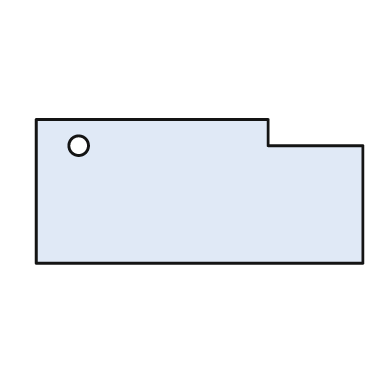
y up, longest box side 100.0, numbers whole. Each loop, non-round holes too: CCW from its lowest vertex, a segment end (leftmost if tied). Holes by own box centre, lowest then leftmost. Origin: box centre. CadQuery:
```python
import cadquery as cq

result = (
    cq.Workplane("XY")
    .moveTo(-50.0, -22.0)
    .lineTo(50.0, -22.0)
    .lineTo(50.0, 14.0)
    .lineTo(21.0, 14.0)
    .lineTo(21.0, 22.0)
    .lineTo(-50.0, 22.0)
    .close()
    .moveTo(-37.0, 14.0)
    .circle(3.0)
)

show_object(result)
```